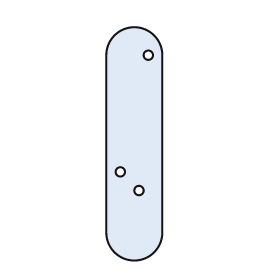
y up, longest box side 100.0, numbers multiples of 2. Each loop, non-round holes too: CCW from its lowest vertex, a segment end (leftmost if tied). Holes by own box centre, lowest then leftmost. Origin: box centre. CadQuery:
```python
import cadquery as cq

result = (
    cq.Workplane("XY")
    .moveTo(-12.0, -38.0)
    .threePointArc((0.0, -50.0), (12.0, -38.0))
    .lineTo(12.0, 38.0)
    .threePointArc((0.0, 50.0), (-12.0, 38.0))
    .close()
    .moveTo(2.0, -20.0)
    .circle(2.0)
    .moveTo(-6.0, -12.0)
    .circle(2.0)
    .moveTo(6.0, 38.0)
    .circle(2.0)
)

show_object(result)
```